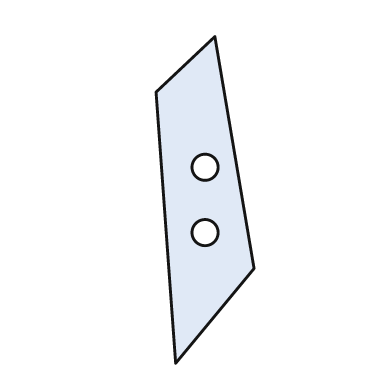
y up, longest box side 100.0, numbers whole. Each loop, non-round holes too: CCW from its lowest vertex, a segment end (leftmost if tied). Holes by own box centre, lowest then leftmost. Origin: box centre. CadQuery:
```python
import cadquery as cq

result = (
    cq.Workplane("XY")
    .moveTo(-9.0, -50.0)
    .lineTo(15.0, -21.0)
    .lineTo(3.0, 50.0)
    .lineTo(-15.0, 33.0)
    .close()
    .moveTo(0.0, -10.0)
    .circle(4.0)
    .moveTo(0.0, 10.0)
    .circle(4.0)
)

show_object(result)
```